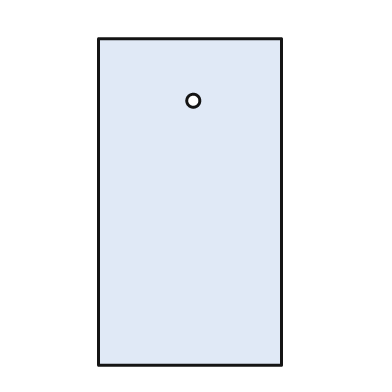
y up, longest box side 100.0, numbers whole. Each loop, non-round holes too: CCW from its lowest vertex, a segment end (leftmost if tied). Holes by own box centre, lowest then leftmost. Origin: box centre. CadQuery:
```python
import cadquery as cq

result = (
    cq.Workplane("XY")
    .moveTo(-28.0, -50.0)
    .lineTo(28.0, -50.0)
    .lineTo(28.0, 50.0)
    .lineTo(-28.0, 50.0)
    .close()
    .moveTo(1.0, 31.0)
    .circle(2.0)
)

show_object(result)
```